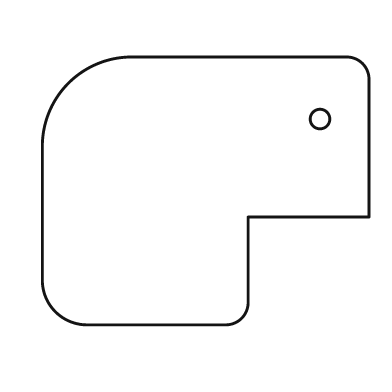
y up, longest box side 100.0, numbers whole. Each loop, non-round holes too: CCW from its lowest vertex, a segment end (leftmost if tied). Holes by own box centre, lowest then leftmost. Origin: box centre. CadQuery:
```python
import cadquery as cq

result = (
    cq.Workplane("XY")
    .moveTo(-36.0, -41.0)
    .lineTo(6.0, -41.0)
    .threePointArc((11.0, -39.0), (13.0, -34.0))
    .lineTo(13.0, -8.0)
    .lineTo(50.0, -8.0)
    .lineTo(50.0, 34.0)
    .threePointArc((48.0, 39.0), (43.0, 41.0))
    .lineTo(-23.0, 41.0)
    .threePointArc((-42.0, 33.0), (-50.0, 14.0))
    .lineTo(-50.0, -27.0)
    .threePointArc((-46.0, -37.0), (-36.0, -41.0))
    .close()
    .moveTo(35.0, 22.0)
    .circle(3.0)
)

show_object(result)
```